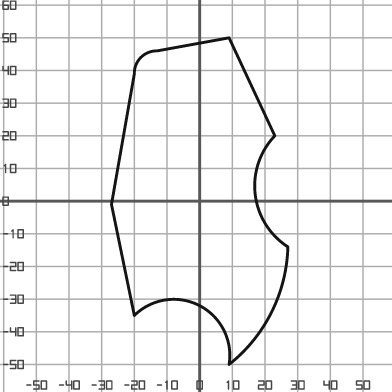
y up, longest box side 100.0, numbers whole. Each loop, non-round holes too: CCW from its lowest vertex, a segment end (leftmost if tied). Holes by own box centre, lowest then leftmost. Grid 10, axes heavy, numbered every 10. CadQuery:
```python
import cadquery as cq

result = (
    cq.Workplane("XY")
    .moveTo(9.0, -50.0)
    .threePointArc((22.0, -34.0), (27.0, -14.0))
    .threePointArc((17.0, 2.0), (23.0, 20.0))
    .lineTo(9.0, 50.0)
    .lineTo(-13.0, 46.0)
    .threePointArc((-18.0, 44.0), (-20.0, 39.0))
    .lineTo(-27.0, -1.0)
    .lineTo(-20.0, -35.0)
    .threePointArc((0.0, -32.0), (9.0, -50.0))
    .close()
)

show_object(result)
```